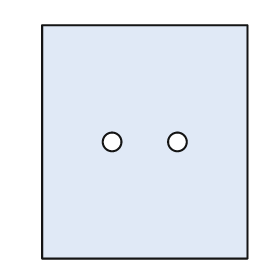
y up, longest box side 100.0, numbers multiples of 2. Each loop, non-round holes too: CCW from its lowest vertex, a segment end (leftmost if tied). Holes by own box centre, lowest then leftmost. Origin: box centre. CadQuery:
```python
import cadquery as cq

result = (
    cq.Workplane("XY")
    .moveTo(-44.0, -50.0)
    .lineTo(44.0, -50.0)
    .lineTo(44.0, 50.0)
    .lineTo(-44.0, 50.0)
    .close()
    .moveTo(-14.0, 0.0)
    .circle(4.0)
    .moveTo(14.0, 0.0)
    .circle(4.0)
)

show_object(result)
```